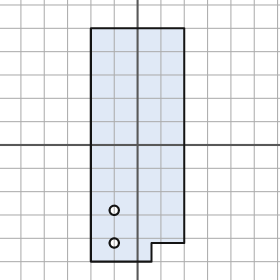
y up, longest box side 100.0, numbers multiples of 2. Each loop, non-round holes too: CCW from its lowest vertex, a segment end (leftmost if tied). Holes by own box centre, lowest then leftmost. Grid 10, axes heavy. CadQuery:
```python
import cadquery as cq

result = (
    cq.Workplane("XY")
    .moveTo(-20.0, -50.0)
    .lineTo(6.0, -50.0)
    .lineTo(6.0, -42.0)
    .lineTo(20.0, -42.0)
    .lineTo(20.0, 50.0)
    .lineTo(-20.0, 50.0)
    .close()
    .moveTo(-10.0, -42.0)
    .circle(2.0)
    .moveTo(-10.0, -28.0)
    .circle(2.0)
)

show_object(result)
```